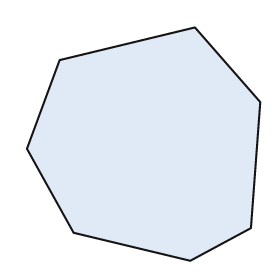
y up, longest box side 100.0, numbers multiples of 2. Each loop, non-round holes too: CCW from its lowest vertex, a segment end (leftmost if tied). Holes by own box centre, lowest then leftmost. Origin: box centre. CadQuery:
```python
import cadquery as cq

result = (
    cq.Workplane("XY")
    .moveTo(20.0, -50.0)
    .lineTo(46.0, -36.0)
    .lineTo(50.0, 18.0)
    .lineTo(22.0, 50.0)
    .lineTo(-36.0, 36.0)
    .lineTo(-50.0, -2.0)
    .lineTo(-30.0, -38.0)
    .close()
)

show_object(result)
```